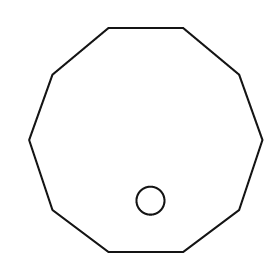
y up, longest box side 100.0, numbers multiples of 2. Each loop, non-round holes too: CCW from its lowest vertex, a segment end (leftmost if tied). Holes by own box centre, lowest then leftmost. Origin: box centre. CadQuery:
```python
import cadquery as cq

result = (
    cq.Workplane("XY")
    .moveTo(-16.0, -48.0)
    .lineTo(16.0, -48.0)
    .lineTo(40.0, -30.0)
    .lineTo(50.0, 0.0)
    .lineTo(40.0, 28.0)
    .lineTo(16.0, 48.0)
    .lineTo(-16.0, 48.0)
    .lineTo(-40.0, 28.0)
    .lineTo(-50.0, 0.0)
    .lineTo(-40.0, -30.0)
    .close()
    .moveTo(2.0, -26.0)
    .circle(6.0)
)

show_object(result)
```